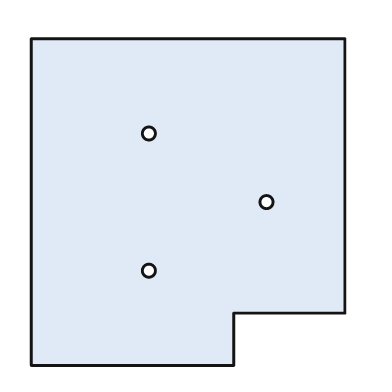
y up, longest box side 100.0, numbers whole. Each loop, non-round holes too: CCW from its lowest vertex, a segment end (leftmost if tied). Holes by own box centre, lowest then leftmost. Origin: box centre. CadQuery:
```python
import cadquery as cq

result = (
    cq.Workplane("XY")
    .moveTo(-48.0, -50.0)
    .lineTo(14.0, -50.0)
    .lineTo(14.0, -34.0)
    .lineTo(48.0, -34.0)
    .lineTo(48.0, 50.0)
    .lineTo(-48.0, 50.0)
    .close()
    .moveTo(-12.0, -21.0)
    .circle(2.0)
    .moveTo(24.0, 0.0)
    .circle(2.0)
    .moveTo(-12.0, 21.0)
    .circle(2.0)
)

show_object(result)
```